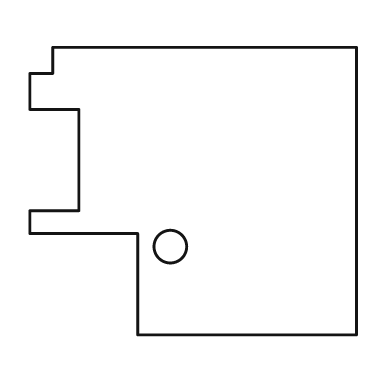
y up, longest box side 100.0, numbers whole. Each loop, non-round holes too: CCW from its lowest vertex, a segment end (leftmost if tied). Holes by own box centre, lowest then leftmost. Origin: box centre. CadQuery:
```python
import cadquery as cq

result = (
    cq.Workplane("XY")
    .moveTo(-17.0, -44.0)
    .lineTo(50.0, -44.0)
    .lineTo(50.0, 44.0)
    .lineTo(-43.0, 44.0)
    .lineTo(-43.0, 36.0)
    .lineTo(-50.0, 36.0)
    .lineTo(-50.0, 25.0)
    .lineTo(-35.0, 25.0)
    .lineTo(-35.0, -6.0)
    .lineTo(-50.0, -6.0)
    .lineTo(-50.0, -13.0)
    .lineTo(-17.0, -13.0)
    .close()
    .moveTo(-7.0, -17.0)
    .circle(5.0)
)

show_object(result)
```